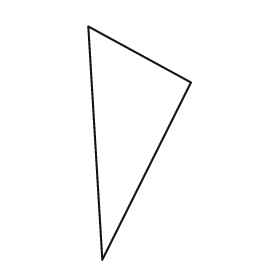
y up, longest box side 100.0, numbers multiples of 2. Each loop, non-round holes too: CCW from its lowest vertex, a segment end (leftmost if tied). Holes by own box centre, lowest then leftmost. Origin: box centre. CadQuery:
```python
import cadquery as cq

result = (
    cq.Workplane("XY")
    .moveTo(-16.0, -50.0)
    .lineTo(22.0, 26.0)
    .lineTo(-22.0, 50.0)
    .close()
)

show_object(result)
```